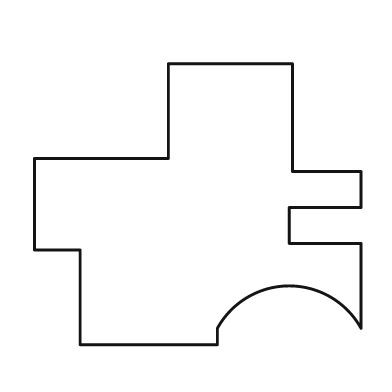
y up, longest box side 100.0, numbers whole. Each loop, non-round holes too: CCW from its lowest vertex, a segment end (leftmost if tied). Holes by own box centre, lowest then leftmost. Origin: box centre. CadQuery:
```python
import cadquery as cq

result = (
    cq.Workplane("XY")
    .moveTo(-36.0, -43.0)
    .lineTo(6.0, -43.0)
    .lineTo(6.0, -38.0)
    .threePointArc((28.0, -25.0), (50.0, -38.0))
    .lineTo(50.0, -12.0)
    .lineTo(28.0, -12.0)
    .lineTo(28.0, -1.0)
    .lineTo(50.0, -1.0)
    .lineTo(50.0, 10.0)
    .lineTo(29.0, 10.0)
    .lineTo(29.0, 43.0)
    .lineTo(-9.0, 43.0)
    .lineTo(-9.0, 14.0)
    .lineTo(-50.0, 14.0)
    .lineTo(-50.0, -14.0)
    .lineTo(-36.0, -14.0)
    .close()
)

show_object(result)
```